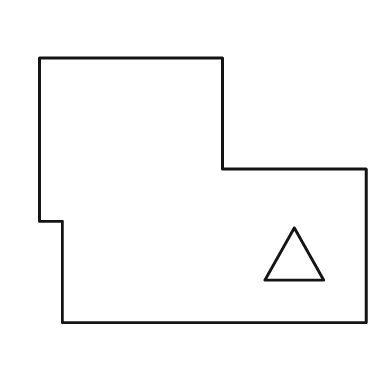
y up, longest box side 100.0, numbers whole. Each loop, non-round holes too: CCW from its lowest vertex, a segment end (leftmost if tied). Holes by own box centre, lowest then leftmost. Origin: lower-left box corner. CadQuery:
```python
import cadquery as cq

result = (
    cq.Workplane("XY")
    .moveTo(7.0, 0.0)
    .lineTo(100.0, 0.0)
    .lineTo(100.0, 47.0)
    .lineTo(56.0, 47.0)
    .lineTo(56.0, 81.0)
    .lineTo(0.0, 81.0)
    .lineTo(0.0, 31.0)
    .lineTo(7.0, 31.0)
    .close()
    .moveTo(69.0, 13.0)
    .lineTo(87.0, 13.0)
    .lineTo(78.0, 29.0)
    .close()
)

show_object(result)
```